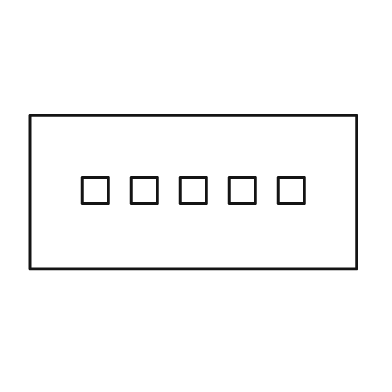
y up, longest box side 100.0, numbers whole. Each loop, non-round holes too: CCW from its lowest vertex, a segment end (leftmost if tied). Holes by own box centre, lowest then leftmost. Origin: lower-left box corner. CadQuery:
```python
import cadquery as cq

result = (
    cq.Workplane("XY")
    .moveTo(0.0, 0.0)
    .lineTo(100.0, 0.0)
    .lineTo(100.0, 47.0)
    .lineTo(0.0, 47.0)
    .close()
    .moveTo(16.0, 20.0)
    .lineTo(24.0, 20.0)
    .lineTo(24.0, 28.0)
    .lineTo(16.0, 28.0)
    .close()
    .moveTo(31.0, 20.0)
    .lineTo(39.0, 20.0)
    .lineTo(39.0, 28.0)
    .lineTo(31.0, 28.0)
    .close()
    .moveTo(46.0, 20.0)
    .lineTo(54.0, 20.0)
    .lineTo(54.0, 28.0)
    .lineTo(46.0, 28.0)
    .close()
    .moveTo(61.0, 20.0)
    .lineTo(69.0, 20.0)
    .lineTo(69.0, 28.0)
    .lineTo(61.0, 28.0)
    .close()
    .moveTo(76.0, 20.0)
    .lineTo(84.0, 20.0)
    .lineTo(84.0, 28.0)
    .lineTo(76.0, 28.0)
    .close()
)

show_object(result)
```